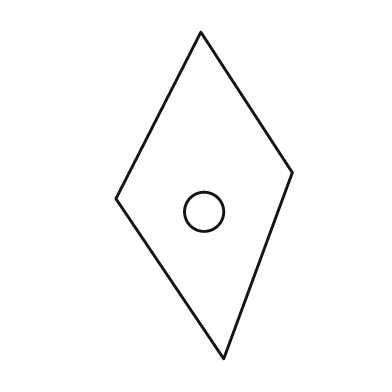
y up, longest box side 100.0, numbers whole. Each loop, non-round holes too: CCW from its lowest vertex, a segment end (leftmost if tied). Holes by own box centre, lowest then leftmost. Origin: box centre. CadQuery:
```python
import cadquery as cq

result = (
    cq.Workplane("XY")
    .moveTo(6.0, -50.0)
    .lineTo(27.0, 7.0)
    .lineTo(-1.0, 50.0)
    .lineTo(-27.0, -1.0)
    .close()
    .moveTo(0.0, -5.0)
    .circle(6.0)
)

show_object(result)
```